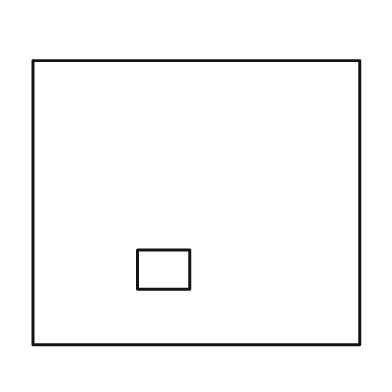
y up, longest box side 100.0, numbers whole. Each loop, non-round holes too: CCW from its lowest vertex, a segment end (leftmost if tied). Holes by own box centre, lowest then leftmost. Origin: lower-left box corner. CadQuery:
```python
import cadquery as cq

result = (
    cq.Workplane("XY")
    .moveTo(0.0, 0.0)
    .lineTo(100.0, 0.0)
    .lineTo(100.0, 87.0)
    .lineTo(0.0, 87.0)
    .close()
    .moveTo(32.0, 17.0)
    .lineTo(48.0, 17.0)
    .lineTo(48.0, 29.0)
    .lineTo(32.0, 29.0)
    .close()
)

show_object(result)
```